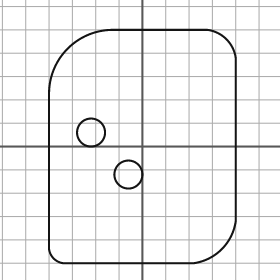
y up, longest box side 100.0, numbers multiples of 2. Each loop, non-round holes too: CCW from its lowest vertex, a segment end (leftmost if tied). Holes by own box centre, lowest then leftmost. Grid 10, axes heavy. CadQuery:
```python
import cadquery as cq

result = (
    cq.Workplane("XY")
    .moveTo(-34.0, -50.0)
    .lineTo(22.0, -50.0)
    .threePointArc((34.0, -44.0), (40.0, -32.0))
    .lineTo(40.0, 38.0)
    .threePointArc((36.0, 46.0), (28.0, 50.0))
    .lineTo(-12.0, 50.0)
    .threePointArc((-32.0, 42.0), (-40.0, 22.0))
    .lineTo(-40.0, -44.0)
    .threePointArc((-38.0, -48.0), (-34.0, -50.0))
    .close()
    .moveTo(-6.0, -12.0)
    .circle(6.0)
    .moveTo(-22.0, 6.0)
    .circle(6.0)
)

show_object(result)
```